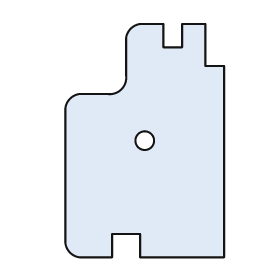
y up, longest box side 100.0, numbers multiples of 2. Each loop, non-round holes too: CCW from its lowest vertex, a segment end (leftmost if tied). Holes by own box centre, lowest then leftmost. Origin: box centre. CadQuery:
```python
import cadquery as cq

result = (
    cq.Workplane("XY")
    .moveTo(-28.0, -50.0)
    .lineTo(-14.0, -50.0)
    .lineTo(-14.0, -40.0)
    .lineTo(-2.0, -40.0)
    .lineTo(-2.0, -50.0)
    .lineTo(34.0, -50.0)
    .lineTo(34.0, 32.0)
    .lineTo(26.0, 32.0)
    .lineTo(26.0, 50.0)
    .lineTo(16.0, 50.0)
    .lineTo(16.0, 40.0)
    .lineTo(8.0, 40.0)
    .lineTo(8.0, 50.0)
    .lineTo(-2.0, 50.0)
    .threePointArc((-6.0, 48.0), (-8.0, 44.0))
    .lineTo(-8.0, 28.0)
    .threePointArc((-10.0, 22.0), (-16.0, 20.0))
    .lineTo(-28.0, 20.0)
    .threePointArc((-32.0, 18.0), (-34.0, 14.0))
    .lineTo(-34.0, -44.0)
    .threePointArc((-32.0, -48.0), (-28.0, -50.0))
    .close()
    .moveTo(0.0, 0.0)
    .circle(4.0)
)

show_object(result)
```